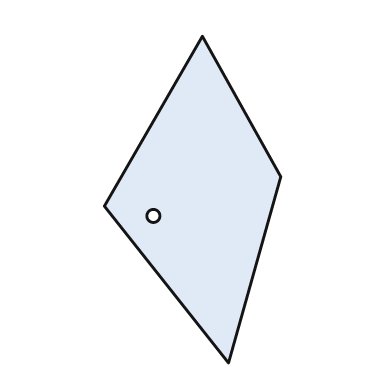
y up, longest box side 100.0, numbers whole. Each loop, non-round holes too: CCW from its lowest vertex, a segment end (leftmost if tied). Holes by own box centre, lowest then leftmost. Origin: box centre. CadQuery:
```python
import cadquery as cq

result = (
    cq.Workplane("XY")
    .moveTo(11.0, -50.0)
    .lineTo(27.0, 7.0)
    .lineTo(3.0, 50.0)
    .lineTo(-27.0, -2.0)
    .close()
    .moveTo(-12.0, -5.0)
    .circle(2.0)
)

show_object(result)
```